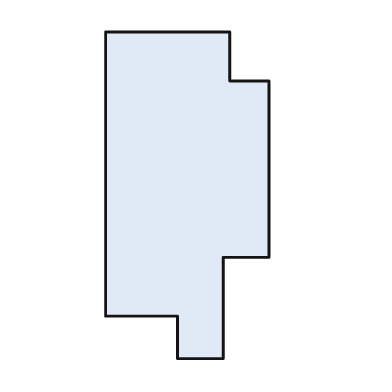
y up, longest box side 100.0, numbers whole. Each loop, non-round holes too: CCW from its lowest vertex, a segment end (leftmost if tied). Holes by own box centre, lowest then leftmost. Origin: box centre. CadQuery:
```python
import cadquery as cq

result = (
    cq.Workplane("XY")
    .moveTo(-3.0, -50.0)
    .lineTo(11.0, -50.0)
    .lineTo(11.0, -19.0)
    .lineTo(25.0, -19.0)
    .lineTo(25.0, 35.0)
    .lineTo(13.0, 35.0)
    .lineTo(13.0, 50.0)
    .lineTo(-25.0, 50.0)
    .lineTo(-25.0, -37.0)
    .lineTo(-3.0, -37.0)
    .close()
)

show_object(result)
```